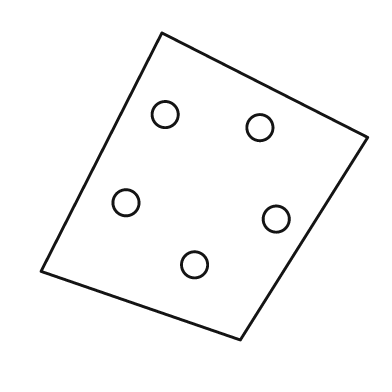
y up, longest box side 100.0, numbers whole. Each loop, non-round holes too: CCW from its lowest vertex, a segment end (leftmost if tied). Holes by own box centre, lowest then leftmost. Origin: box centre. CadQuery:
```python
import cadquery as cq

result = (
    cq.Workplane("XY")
    .moveTo(11.0, -47.0)
    .lineTo(50.0, 15.0)
    .lineTo(-13.0, 47.0)
    .lineTo(-50.0, -26.0)
    .close()
    .moveTo(-3.0, -24.0)
    .circle(4.0)
    .moveTo(22.0, -10.0)
    .circle(4.0)
    .moveTo(-24.0, -5.0)
    .circle(4.0)
    .moveTo(17.0, 18.0)
    .circle(4.0)
    .moveTo(-12.0, 22.0)
    .circle(4.0)
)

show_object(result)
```